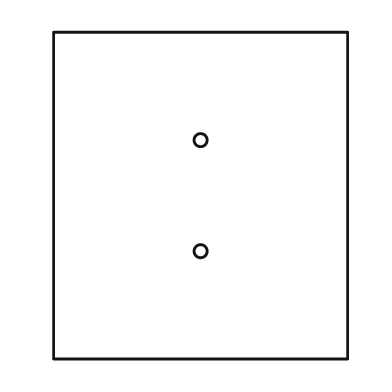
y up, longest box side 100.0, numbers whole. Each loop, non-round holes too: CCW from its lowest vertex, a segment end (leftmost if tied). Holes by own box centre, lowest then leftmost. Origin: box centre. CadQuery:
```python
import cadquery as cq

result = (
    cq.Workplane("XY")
    .moveTo(-45.0, -50.0)
    .lineTo(45.0, -50.0)
    .lineTo(45.0, 50.0)
    .lineTo(-45.0, 50.0)
    .close()
    .moveTo(0.0, -17.0)
    .circle(2.0)
    .moveTo(0.0, 17.0)
    .circle(2.0)
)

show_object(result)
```